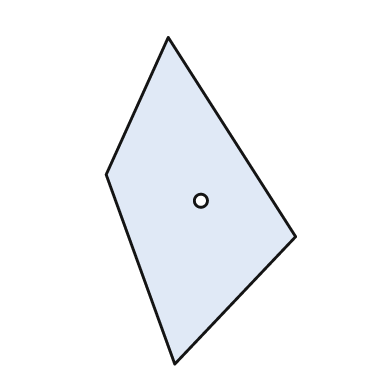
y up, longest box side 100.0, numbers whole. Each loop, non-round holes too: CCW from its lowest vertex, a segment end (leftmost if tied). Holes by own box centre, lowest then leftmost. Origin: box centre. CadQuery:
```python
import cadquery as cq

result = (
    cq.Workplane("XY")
    .moveTo(-8.0, -50.0)
    .lineTo(29.0, -11.0)
    .lineTo(-10.0, 50.0)
    .lineTo(-29.0, 8.0)
    .close()
    .moveTo(0.0, 0.0)
    .circle(2.0)
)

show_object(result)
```